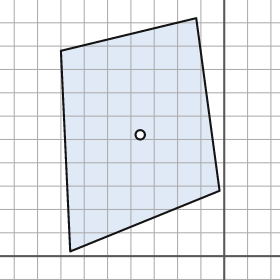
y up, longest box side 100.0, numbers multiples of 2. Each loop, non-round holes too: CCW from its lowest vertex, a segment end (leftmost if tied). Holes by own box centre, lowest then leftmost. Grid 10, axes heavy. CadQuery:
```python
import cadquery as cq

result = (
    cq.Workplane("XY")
    .moveTo(-66.0, 2.0)
    .lineTo(-2.0, 28.0)
    .lineTo(-12.0, 102.0)
    .lineTo(-70.0, 88.0)
    .close()
    .moveTo(-36.0, 52.0)
    .circle(2.0)
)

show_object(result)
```